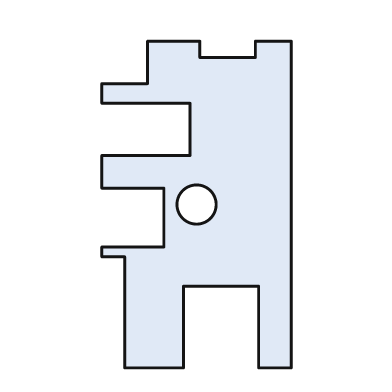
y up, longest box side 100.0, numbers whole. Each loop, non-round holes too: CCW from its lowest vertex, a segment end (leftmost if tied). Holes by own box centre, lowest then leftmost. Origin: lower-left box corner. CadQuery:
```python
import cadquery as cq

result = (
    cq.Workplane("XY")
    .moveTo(7.0, 0.0)
    .lineTo(25.0, 0.0)
    .lineTo(25.0, 25.0)
    .lineTo(48.0, 25.0)
    .lineTo(48.0, 0.0)
    .lineTo(58.0, 0.0)
    .lineTo(58.0, 100.0)
    .lineTo(47.0, 100.0)
    .lineTo(47.0, 95.0)
    .lineTo(30.0, 95.0)
    .lineTo(30.0, 100.0)
    .lineTo(14.0, 100.0)
    .lineTo(14.0, 87.0)
    .lineTo(0.0, 87.0)
    .lineTo(0.0, 81.0)
    .lineTo(27.0, 81.0)
    .lineTo(27.0, 65.0)
    .lineTo(0.0, 65.0)
    .lineTo(0.0, 55.0)
    .lineTo(19.0, 55.0)
    .lineTo(19.0, 37.0)
    .lineTo(0.0, 37.0)
    .lineTo(0.0, 34.0)
    .lineTo(7.0, 34.0)
    .close()
    .moveTo(29.0, 50.0)
    .circle(6.0)
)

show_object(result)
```